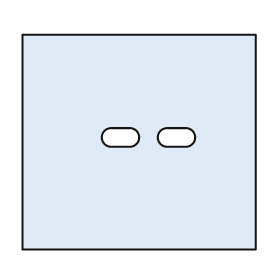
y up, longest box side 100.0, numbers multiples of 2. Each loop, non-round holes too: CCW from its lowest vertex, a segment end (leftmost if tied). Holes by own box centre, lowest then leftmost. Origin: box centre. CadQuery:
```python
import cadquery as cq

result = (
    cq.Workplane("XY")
    .moveTo(-50.0, -46.0)
    .lineTo(50.0, -46.0)
    .lineTo(50.0, 46.0)
    .lineTo(-50.0, 46.0)
    .close()
    .moveTo(-12.0, -2.0)
    .lineTo(-4.0, -2.0)
    .threePointArc((0.0, 2.0), (-4.0, 6.0))
    .lineTo(-12.0, 6.0)
    .threePointArc((-16.0, 2.0), (-12.0, -2.0))
    .close()
    .moveTo(12.0, -2.0)
    .lineTo(20.0, -2.0)
    .threePointArc((24.0, 2.0), (20.0, 6.0))
    .lineTo(12.0, 6.0)
    .threePointArc((8.0, 2.0), (12.0, -2.0))
    .close()
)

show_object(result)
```